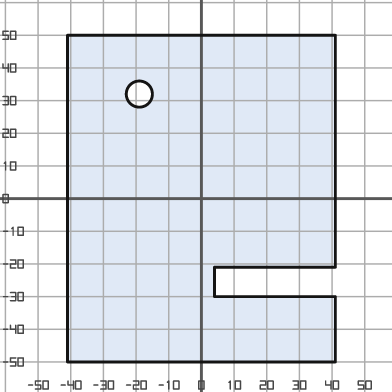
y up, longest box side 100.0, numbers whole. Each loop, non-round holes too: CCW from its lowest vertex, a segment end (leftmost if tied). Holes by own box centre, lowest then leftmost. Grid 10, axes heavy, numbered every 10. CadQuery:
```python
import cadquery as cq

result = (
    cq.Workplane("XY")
    .moveTo(-41.0, -50.0)
    .lineTo(41.0, -50.0)
    .lineTo(41.0, -30.0)
    .lineTo(4.0, -30.0)
    .lineTo(4.0, -21.0)
    .lineTo(41.0, -21.0)
    .lineTo(41.0, 50.0)
    .lineTo(-41.0, 50.0)
    .close()
    .moveTo(-19.0, 32.0)
    .circle(4.0)
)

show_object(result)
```